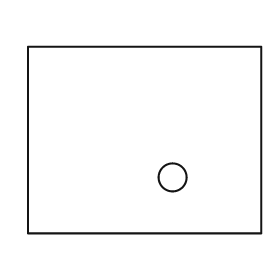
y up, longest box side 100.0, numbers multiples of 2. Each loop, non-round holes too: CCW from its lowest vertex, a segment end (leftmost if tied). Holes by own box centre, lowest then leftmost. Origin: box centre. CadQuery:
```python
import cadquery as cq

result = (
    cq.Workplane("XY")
    .moveTo(-50.0, -40.0)
    .lineTo(50.0, -40.0)
    .lineTo(50.0, 40.0)
    .lineTo(-50.0, 40.0)
    .close()
    .moveTo(12.0, -16.0)
    .circle(6.0)
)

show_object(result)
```